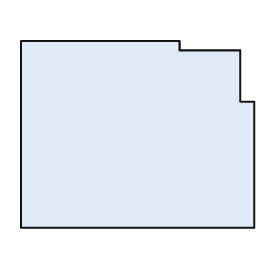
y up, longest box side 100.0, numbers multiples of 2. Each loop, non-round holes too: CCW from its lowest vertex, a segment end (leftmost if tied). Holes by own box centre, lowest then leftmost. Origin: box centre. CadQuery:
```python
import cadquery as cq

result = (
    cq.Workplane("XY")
    .moveTo(-50.0, -40.0)
    .lineTo(50.0, -40.0)
    .lineTo(50.0, 14.0)
    .lineTo(44.0, 14.0)
    .lineTo(44.0, 36.0)
    .lineTo(18.0, 36.0)
    .lineTo(18.0, 40.0)
    .lineTo(-50.0, 40.0)
    .close()
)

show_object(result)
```